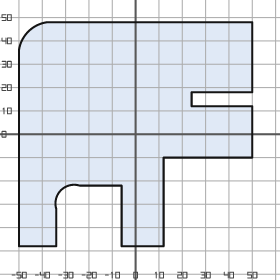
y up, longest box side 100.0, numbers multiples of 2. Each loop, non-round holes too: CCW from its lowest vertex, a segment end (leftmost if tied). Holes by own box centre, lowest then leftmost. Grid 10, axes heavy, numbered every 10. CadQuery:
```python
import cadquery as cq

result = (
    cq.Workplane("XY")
    .moveTo(-50.0, -48.0)
    .lineTo(-34.0, -48.0)
    .lineTo(-34.0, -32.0)
    .threePointArc((-32.0, -24.0), (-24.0, -22.0))
    .lineTo(-6.0, -22.0)
    .lineTo(-6.0, -48.0)
    .lineTo(12.0, -48.0)
    .lineTo(12.0, -10.0)
    .lineTo(50.0, -10.0)
    .lineTo(50.0, 12.0)
    .lineTo(24.0, 12.0)
    .lineTo(24.0, 18.0)
    .lineTo(50.0, 18.0)
    .lineTo(50.0, 48.0)
    .lineTo(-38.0, 48.0)
    .threePointArc((-46.0, 44.0), (-50.0, 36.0))
    .close()
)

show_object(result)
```